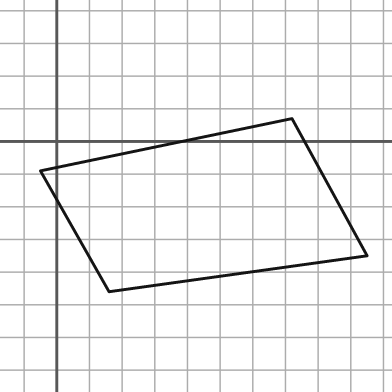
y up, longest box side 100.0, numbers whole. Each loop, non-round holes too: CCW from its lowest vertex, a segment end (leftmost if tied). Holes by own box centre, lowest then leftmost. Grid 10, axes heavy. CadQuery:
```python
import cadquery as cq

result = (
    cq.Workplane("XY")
    .moveTo(16.0, -46.0)
    .lineTo(95.0, -35.0)
    .lineTo(72.0, 7.0)
    .lineTo(-5.0, -9.0)
    .close()
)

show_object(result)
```